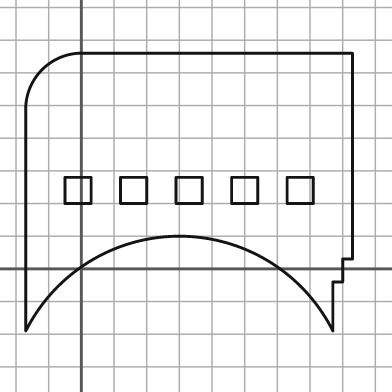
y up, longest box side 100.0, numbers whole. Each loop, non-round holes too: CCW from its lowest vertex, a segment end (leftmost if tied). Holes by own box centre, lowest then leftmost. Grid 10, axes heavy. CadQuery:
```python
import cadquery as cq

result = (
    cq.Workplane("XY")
    .moveTo(-17.0, -19.0)
    .threePointArc((30.0, 10.0), (77.0, -19.0))
    .lineTo(77.0, -4.0)
    .lineTo(80.0, -4.0)
    .lineTo(80.0, 3.0)
    .lineTo(83.0, 3.0)
    .lineTo(83.0, 66.0)
    .lineTo(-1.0, 66.0)
    .threePointArc((-12.0, 61.0), (-17.0, 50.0))
    .close()
    .moveTo(-5.0, 20.0)
    .lineTo(3.0, 20.0)
    .lineTo(3.0, 28.0)
    .lineTo(-5.0, 28.0)
    .close()
    .moveTo(12.0, 20.0)
    .lineTo(20.0, 20.0)
    .lineTo(20.0, 28.0)
    .lineTo(12.0, 28.0)
    .close()
    .moveTo(29.0, 20.0)
    .lineTo(37.0, 20.0)
    .lineTo(37.0, 28.0)
    .lineTo(29.0, 28.0)
    .close()
    .moveTo(46.0, 20.0)
    .lineTo(54.0, 20.0)
    .lineTo(54.0, 28.0)
    .lineTo(46.0, 28.0)
    .close()
    .moveTo(63.0, 20.0)
    .lineTo(71.0, 20.0)
    .lineTo(71.0, 28.0)
    .lineTo(63.0, 28.0)
    .close()
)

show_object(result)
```